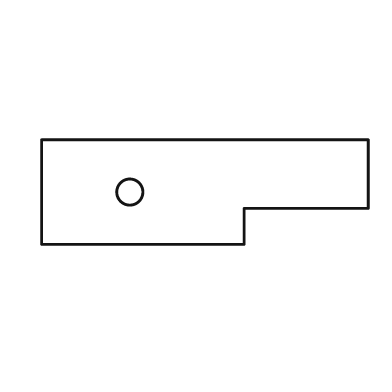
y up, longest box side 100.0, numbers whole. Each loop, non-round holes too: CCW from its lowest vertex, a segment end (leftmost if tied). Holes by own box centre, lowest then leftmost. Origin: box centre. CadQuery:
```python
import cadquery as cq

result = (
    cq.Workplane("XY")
    .moveTo(-50.0, -16.0)
    .lineTo(12.0, -16.0)
    .lineTo(12.0, -5.0)
    .lineTo(50.0, -5.0)
    .lineTo(50.0, 16.0)
    .lineTo(-50.0, 16.0)
    .close()
    .moveTo(-23.0, 0.0)
    .circle(4.0)
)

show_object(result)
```